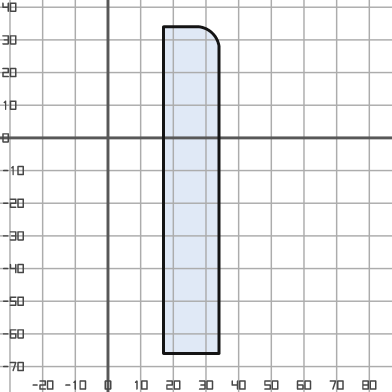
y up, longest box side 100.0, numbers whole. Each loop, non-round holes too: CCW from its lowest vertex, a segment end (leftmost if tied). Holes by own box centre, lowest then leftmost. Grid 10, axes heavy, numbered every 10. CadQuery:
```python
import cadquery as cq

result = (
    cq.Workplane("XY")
    .moveTo(17.0, -66.0)
    .lineTo(34.0, -66.0)
    .lineTo(34.0, 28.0)
    .threePointArc((32.0, 32.0), (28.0, 34.0))
    .lineTo(17.0, 34.0)
    .close()
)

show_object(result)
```